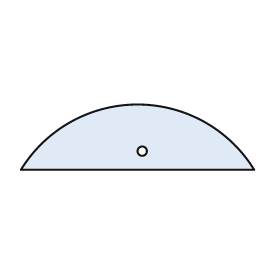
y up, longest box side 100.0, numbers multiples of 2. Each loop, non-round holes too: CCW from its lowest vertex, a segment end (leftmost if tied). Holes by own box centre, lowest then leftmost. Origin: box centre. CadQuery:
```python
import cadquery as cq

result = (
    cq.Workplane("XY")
    .moveTo(-50.0, -14.0)
    .lineTo(50.0, -14.0)
    .threePointArc((0.0, 14.0), (-50.0, -14.0))
    .close()
    .moveTo(2.0, -6.0)
    .circle(2.0)
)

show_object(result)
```